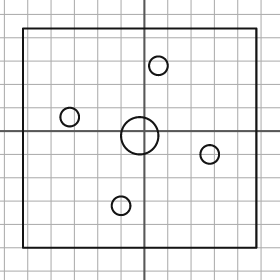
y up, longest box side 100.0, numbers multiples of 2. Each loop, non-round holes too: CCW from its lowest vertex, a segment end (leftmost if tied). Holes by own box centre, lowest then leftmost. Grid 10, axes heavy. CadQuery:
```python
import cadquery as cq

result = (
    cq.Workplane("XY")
    .moveTo(-52.0, -50.0)
    .lineTo(48.0, -50.0)
    .lineTo(48.0, 44.0)
    .lineTo(-52.0, 44.0)
    .close()
    .moveTo(-10.0, -32.0)
    .circle(4.0)
    .moveTo(28.0, -10.0)
    .circle(4.0)
    .moveTo(-2.0, -2.0)
    .circle(8.0)
    .moveTo(-32.0, 6.0)
    .circle(4.0)
    .moveTo(6.0, 28.0)
    .circle(4.0)
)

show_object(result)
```